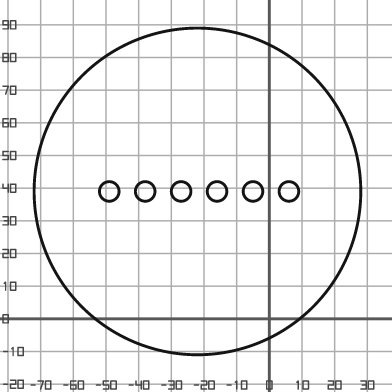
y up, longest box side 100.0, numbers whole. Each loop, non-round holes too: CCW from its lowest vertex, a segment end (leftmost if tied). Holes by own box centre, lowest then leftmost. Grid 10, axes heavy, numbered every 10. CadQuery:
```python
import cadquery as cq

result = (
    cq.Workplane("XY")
    .moveTo(-22.0, 39.0)
    .circle(50.0)
    .moveTo(-49.0, 39.0)
    .circle(3.0)
    .moveTo(-38.0, 39.0)
    .circle(3.0)
    .moveTo(-27.0, 39.0)
    .circle(3.0)
    .moveTo(-16.0, 39.0)
    .circle(3.0)
    .moveTo(-5.0, 39.0)
    .circle(3.0)
    .moveTo(6.0, 39.0)
    .circle(3.0)
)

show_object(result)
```